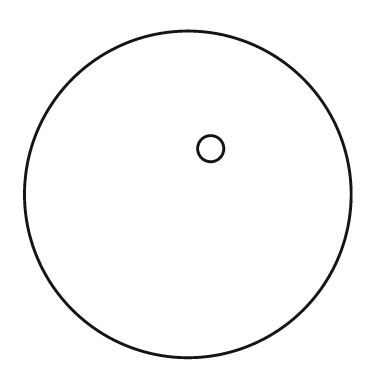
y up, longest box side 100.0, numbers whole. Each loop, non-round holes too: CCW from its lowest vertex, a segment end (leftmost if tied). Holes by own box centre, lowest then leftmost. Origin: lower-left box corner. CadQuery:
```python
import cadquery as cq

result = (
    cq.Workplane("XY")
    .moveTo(50.0, 50.0)
    .circle(50.0)
    .moveTo(57.0, 64.0)
    .circle(4.0)
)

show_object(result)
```